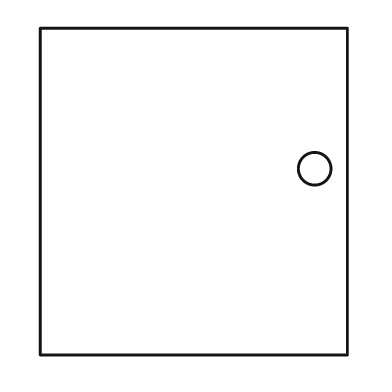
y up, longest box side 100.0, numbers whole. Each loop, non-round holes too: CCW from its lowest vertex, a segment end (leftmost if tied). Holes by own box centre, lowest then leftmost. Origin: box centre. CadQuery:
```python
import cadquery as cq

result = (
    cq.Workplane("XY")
    .moveTo(-47.0, -50.0)
    .lineTo(47.0, -50.0)
    .lineTo(47.0, 50.0)
    .lineTo(-47.0, 50.0)
    .close()
    .moveTo(37.0, 7.0)
    .circle(5.0)
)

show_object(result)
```